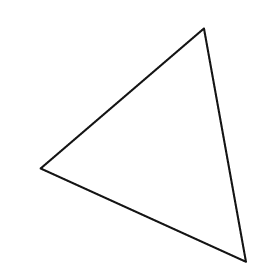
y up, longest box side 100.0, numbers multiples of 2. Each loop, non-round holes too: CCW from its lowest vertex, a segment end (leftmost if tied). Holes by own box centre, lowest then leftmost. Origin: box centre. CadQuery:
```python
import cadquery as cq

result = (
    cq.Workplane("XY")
    .moveTo(44.0, -50.0)
    .lineTo(26.0, 50.0)
    .lineTo(-44.0, -10.0)
    .close()
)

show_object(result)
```